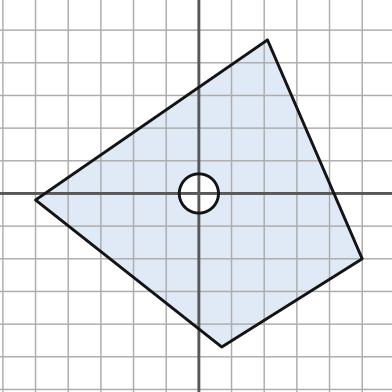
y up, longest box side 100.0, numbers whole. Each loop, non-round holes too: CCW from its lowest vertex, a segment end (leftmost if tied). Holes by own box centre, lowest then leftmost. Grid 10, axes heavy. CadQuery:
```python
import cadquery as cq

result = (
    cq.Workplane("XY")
    .moveTo(7.0, -47.0)
    .lineTo(50.0, -20.0)
    .lineTo(21.0, 47.0)
    .lineTo(-50.0, -2.0)
    .close()
    .moveTo(0.0, 0.0)
    .circle(6.0)
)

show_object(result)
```